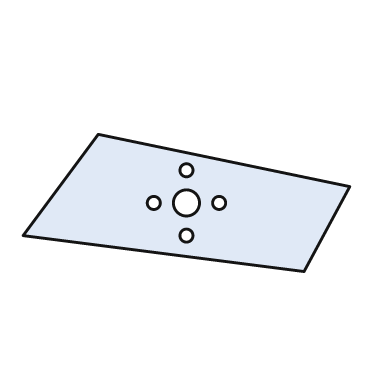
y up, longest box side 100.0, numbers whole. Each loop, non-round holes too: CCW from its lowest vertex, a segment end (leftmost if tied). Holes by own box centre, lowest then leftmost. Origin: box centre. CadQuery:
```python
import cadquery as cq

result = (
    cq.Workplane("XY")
    .moveTo(36.0, -21.0)
    .lineTo(50.0, 5.0)
    .lineTo(-27.0, 21.0)
    .lineTo(-50.0, -10.0)
    .close()
    .moveTo(0.0, -10.0)
    .circle(2.0)
    .moveTo(-10.0, 0.0)
    .circle(2.0)
    .moveTo(0.0, 0.0)
    .circle(4.0)
    .moveTo(10.0, 0.0)
    .circle(2.0)
    .moveTo(0.0, 10.0)
    .circle(2.0)
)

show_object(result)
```